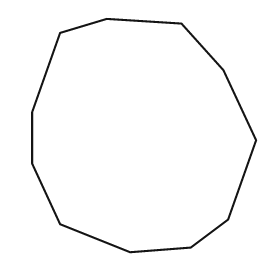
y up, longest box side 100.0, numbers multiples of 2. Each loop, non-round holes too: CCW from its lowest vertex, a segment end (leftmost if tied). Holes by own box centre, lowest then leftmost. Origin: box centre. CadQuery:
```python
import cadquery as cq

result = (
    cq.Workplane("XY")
    .moveTo(-6.0, -50.0)
    .lineTo(20.0, -48.0)
    .lineTo(36.0, -36.0)
    .lineTo(48.0, -2.0)
    .lineTo(34.0, 28.0)
    .lineTo(16.0, 48.0)
    .lineTo(-16.0, 50.0)
    .lineTo(-36.0, 44.0)
    .lineTo(-48.0, 10.0)
    .lineTo(-48.0, -12.0)
    .lineTo(-36.0, -38.0)
    .close()
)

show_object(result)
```